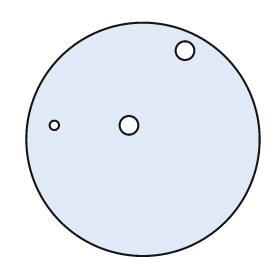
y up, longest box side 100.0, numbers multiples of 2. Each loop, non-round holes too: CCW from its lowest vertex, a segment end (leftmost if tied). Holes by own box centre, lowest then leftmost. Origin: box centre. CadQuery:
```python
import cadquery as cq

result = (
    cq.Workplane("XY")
    .moveTo(0.0, 0.0)
    .circle(50.0)
    .moveTo(-38.0, 6.0)
    .circle(2.0)
    .moveTo(-6.0, 6.0)
    .circle(4.0)
    .moveTo(18.0, 38.0)
    .circle(4.0)
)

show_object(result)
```